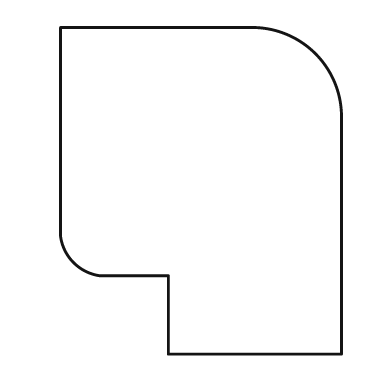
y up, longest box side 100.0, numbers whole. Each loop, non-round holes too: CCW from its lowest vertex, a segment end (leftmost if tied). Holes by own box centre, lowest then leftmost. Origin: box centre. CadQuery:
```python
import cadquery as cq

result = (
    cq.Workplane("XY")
    .moveTo(-10.0, -50.0)
    .lineTo(43.0, -50.0)
    .lineTo(43.0, 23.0)
    .threePointArc((35.0, 42.0), (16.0, 50.0))
    .lineTo(-43.0, 50.0)
    .lineTo(-43.0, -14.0)
    .threePointArc((-39.0, -22.0), (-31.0, -26.0))
    .lineTo(-10.0, -26.0)
    .close()
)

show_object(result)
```